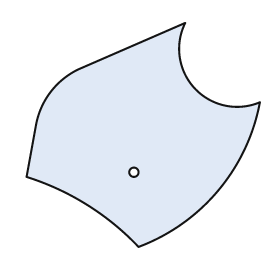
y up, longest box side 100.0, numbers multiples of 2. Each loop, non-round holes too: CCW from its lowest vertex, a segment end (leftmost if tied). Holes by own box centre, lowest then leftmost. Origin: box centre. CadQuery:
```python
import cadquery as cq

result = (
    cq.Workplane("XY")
    .moveTo(-2.0, -48.0)
    .threePointArc((32.0, -24.0), (50.0, 14.0))
    .threePointArc((22.0, 20.0), (18.0, 48.0))
    .lineTo(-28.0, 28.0)
    .threePointArc((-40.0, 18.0), (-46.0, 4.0))
    .lineTo(-50.0, -18.0)
    .threePointArc((-24.0, -30.0), (-2.0, -48.0))
    .close()
    .moveTo(-4.0, -16.0)
    .circle(2.0)
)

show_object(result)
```